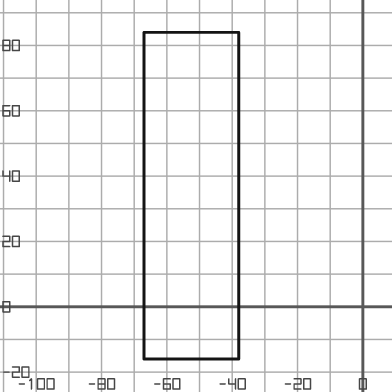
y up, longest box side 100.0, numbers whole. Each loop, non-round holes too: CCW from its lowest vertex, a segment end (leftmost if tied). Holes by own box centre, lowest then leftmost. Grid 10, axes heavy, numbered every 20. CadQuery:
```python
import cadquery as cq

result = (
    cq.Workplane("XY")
    .moveTo(-67.0, -16.0)
    .lineTo(-38.0, -16.0)
    .lineTo(-38.0, 84.0)
    .lineTo(-67.0, 84.0)
    .close()
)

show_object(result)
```